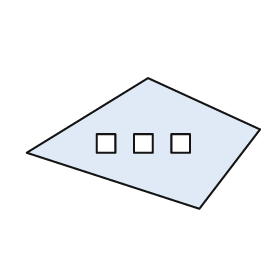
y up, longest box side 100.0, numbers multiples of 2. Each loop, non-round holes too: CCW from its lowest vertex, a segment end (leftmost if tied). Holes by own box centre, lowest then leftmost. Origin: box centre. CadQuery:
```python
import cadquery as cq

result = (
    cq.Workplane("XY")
    .moveTo(24.0, -28.0)
    .lineTo(50.0, 6.0)
    .lineTo(2.0, 28.0)
    .lineTo(-50.0, -4.0)
    .close()
    .moveTo(-20.0, -4.0)
    .lineTo(-12.0, -4.0)
    .lineTo(-12.0, 4.0)
    .lineTo(-20.0, 4.0)
    .close()
    .moveTo(-4.0, -4.0)
    .lineTo(4.0, -4.0)
    .lineTo(4.0, 4.0)
    .lineTo(-4.0, 4.0)
    .close()
    .moveTo(12.0, -4.0)
    .lineTo(20.0, -4.0)
    .lineTo(20.0, 4.0)
    .lineTo(12.0, 4.0)
    .close()
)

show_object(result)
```